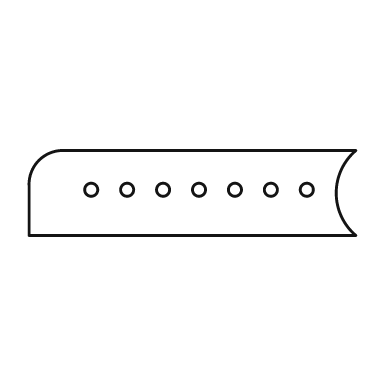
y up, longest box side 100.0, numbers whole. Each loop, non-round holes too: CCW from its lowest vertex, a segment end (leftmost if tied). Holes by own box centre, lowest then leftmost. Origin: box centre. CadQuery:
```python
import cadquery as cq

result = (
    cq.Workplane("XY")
    .moveTo(-50.0, -13.0)
    .lineTo(50.0, -13.0)
    .threePointArc((44.0, 0.0), (50.0, 13.0))
    .lineTo(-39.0, 13.0)
    .threePointArc((-47.0, 10.0), (-50.0, 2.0))
    .close()
    .moveTo(-31.0, 1.0)
    .circle(2.0)
    .moveTo(-20.0, 1.0)
    .circle(2.0)
    .moveTo(-9.0, 1.0)
    .circle(2.0)
    .moveTo(2.0, 1.0)
    .circle(2.0)
    .moveTo(13.0, 1.0)
    .circle(2.0)
    .moveTo(24.0, 1.0)
    .circle(2.0)
    .moveTo(35.0, 1.0)
    .circle(2.0)
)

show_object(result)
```